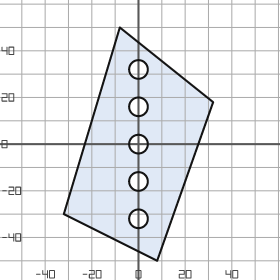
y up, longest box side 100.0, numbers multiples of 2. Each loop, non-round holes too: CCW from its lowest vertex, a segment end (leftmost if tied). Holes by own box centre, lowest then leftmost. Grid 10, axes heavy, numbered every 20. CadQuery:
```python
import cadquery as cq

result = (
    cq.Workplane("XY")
    .moveTo(8.0, -50.0)
    .lineTo(32.0, 18.0)
    .lineTo(-8.0, 50.0)
    .lineTo(-32.0, -30.0)
    .close()
    .moveTo(0.0, -32.0)
    .circle(4.0)
    .moveTo(0.0, -16.0)
    .circle(4.0)
    .moveTo(0.0, 0.0)
    .circle(4.0)
    .moveTo(0.0, 16.0)
    .circle(4.0)
    .moveTo(0.0, 32.0)
    .circle(4.0)
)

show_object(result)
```